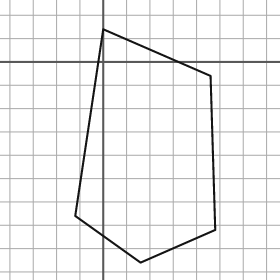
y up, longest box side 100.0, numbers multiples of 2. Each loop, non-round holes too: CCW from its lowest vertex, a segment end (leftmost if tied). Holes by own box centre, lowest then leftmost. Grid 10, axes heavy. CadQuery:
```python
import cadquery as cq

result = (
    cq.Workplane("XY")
    .moveTo(16.0, -86.0)
    .lineTo(48.0, -72.0)
    .lineTo(46.0, -6.0)
    .lineTo(0.0, 14.0)
    .lineTo(-12.0, -66.0)
    .close()
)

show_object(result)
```